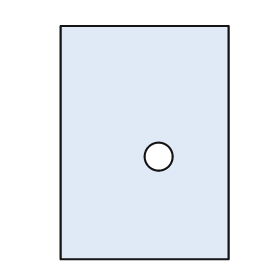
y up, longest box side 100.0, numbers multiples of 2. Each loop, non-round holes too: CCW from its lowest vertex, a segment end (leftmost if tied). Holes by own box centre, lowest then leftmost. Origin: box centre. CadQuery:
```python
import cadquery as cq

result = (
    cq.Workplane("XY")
    .moveTo(-36.0, -50.0)
    .lineTo(36.0, -50.0)
    .lineTo(36.0, 50.0)
    .lineTo(-36.0, 50.0)
    .close()
    .moveTo(6.0, -6.0)
    .circle(6.0)
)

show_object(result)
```